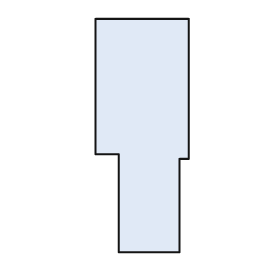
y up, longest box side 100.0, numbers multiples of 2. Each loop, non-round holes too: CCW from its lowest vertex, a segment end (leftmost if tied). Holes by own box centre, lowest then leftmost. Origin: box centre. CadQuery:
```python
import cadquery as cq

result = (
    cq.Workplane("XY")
    .moveTo(-10.0, -50.0)
    .lineTo(16.0, -50.0)
    .lineTo(16.0, -10.0)
    .lineTo(20.0, -10.0)
    .lineTo(20.0, 50.0)
    .lineTo(-20.0, 50.0)
    .lineTo(-20.0, -8.0)
    .lineTo(-10.0, -8.0)
    .close()
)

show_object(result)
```